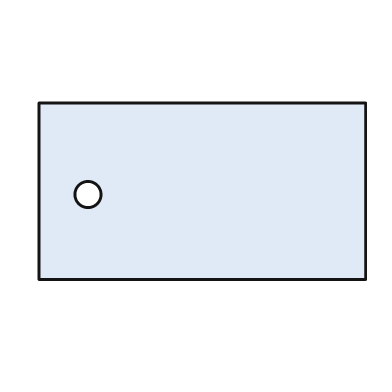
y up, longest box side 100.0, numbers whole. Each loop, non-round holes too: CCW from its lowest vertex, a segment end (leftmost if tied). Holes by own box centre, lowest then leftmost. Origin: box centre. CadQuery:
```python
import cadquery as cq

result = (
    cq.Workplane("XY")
    .moveTo(-50.0, -27.0)
    .lineTo(50.0, -27.0)
    .lineTo(50.0, 27.0)
    .lineTo(-50.0, 27.0)
    .close()
    .moveTo(-35.0, -1.0)
    .circle(4.0)
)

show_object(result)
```